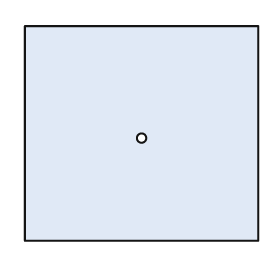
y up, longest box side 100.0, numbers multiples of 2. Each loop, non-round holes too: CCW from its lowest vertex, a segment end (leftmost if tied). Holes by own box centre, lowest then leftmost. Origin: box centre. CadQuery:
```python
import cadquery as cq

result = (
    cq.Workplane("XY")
    .moveTo(-50.0, -46.0)
    .lineTo(50.0, -46.0)
    .lineTo(50.0, 46.0)
    .lineTo(-50.0, 46.0)
    .close()
    .moveTo(0.0, -2.0)
    .circle(2.0)
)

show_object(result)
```